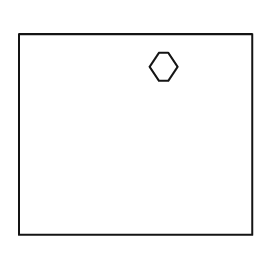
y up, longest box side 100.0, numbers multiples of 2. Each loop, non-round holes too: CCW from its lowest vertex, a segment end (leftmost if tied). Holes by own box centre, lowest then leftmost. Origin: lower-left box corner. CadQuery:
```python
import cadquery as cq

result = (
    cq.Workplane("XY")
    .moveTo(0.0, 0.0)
    .lineTo(100.0, 0.0)
    .lineTo(100.0, 86.0)
    .lineTo(0.0, 86.0)
    .close()
    .moveTo(60.0, 66.0)
    .lineTo(64.0, 66.0)
    .lineTo(68.0, 72.0)
    .lineTo(64.0, 78.0)
    .lineTo(60.0, 78.0)
    .lineTo(56.0, 72.0)
    .close()
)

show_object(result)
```